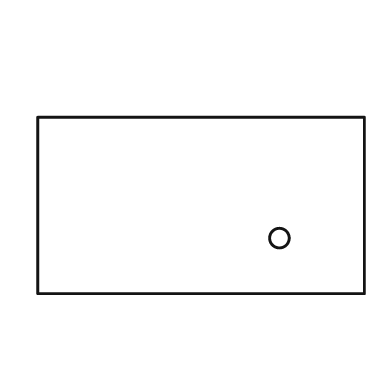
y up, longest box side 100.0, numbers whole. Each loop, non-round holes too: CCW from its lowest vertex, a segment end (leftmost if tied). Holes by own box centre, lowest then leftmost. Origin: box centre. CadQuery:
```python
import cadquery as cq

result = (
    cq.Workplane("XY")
    .moveTo(-50.0, -27.0)
    .lineTo(50.0, -27.0)
    .lineTo(50.0, 27.0)
    .lineTo(-50.0, 27.0)
    .close()
    .moveTo(24.0, -10.0)
    .circle(3.0)
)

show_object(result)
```